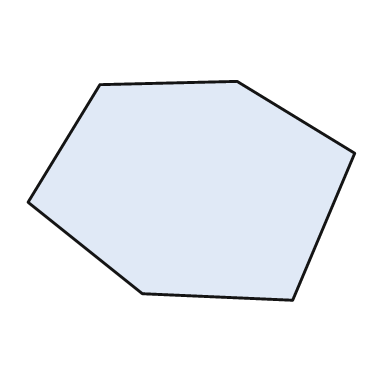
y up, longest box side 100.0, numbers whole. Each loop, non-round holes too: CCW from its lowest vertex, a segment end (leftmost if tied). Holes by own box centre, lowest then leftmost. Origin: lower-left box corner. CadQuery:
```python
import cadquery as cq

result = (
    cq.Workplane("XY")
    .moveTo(81.0, 0.0)
    .lineTo(100.0, 45.0)
    .lineTo(64.0, 67.0)
    .lineTo(22.0, 66.0)
    .lineTo(0.0, 30.0)
    .lineTo(35.0, 2.0)
    .close()
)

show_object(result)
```